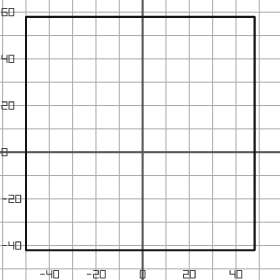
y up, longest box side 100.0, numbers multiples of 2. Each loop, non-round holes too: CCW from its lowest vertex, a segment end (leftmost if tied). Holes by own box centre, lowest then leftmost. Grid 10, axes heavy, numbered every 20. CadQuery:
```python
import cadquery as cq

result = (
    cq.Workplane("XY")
    .moveTo(-50.0, -42.0)
    .lineTo(48.0, -42.0)
    .lineTo(48.0, 58.0)
    .lineTo(-50.0, 58.0)
    .close()
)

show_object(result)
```